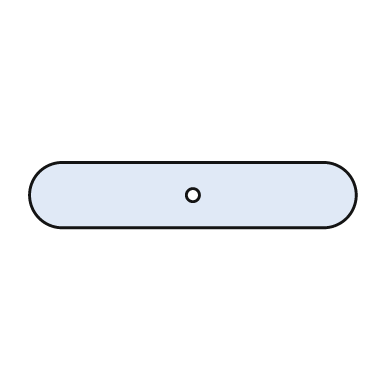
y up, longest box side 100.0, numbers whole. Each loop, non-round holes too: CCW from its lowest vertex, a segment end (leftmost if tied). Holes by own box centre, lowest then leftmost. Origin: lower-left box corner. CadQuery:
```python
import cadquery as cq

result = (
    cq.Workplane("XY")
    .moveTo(10.0, 0.0)
    .lineTo(90.0, 0.0)
    .threePointArc((100.0, 10.0), (90.0, 20.0))
    .lineTo(10.0, 20.0)
    .threePointArc((0.0, 10.0), (10.0, 0.0))
    .close()
    .moveTo(50.0, 10.0)
    .circle(2.0)
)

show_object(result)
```